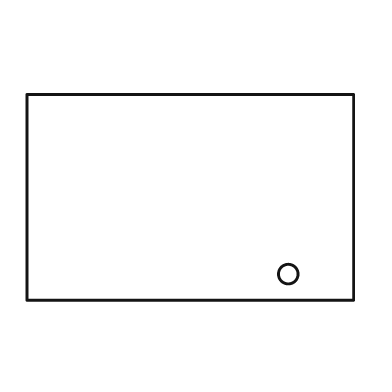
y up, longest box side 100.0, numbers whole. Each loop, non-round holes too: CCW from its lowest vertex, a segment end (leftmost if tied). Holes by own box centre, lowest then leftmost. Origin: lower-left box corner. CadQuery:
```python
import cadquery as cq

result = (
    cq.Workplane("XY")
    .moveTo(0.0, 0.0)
    .lineTo(100.0, 0.0)
    .lineTo(100.0, 63.0)
    .lineTo(0.0, 63.0)
    .close()
    .moveTo(80.0, 8.0)
    .circle(3.0)
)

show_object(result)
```